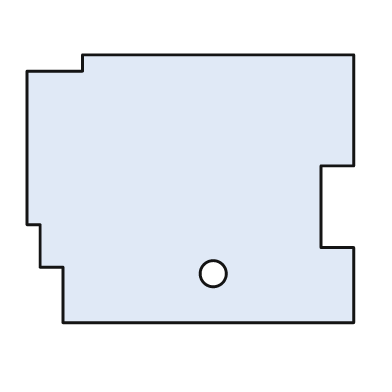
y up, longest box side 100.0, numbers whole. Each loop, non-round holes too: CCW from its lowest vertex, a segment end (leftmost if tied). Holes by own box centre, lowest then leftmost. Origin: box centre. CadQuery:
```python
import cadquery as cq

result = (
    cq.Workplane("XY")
    .moveTo(-39.0, -41.0)
    .lineTo(50.0, -41.0)
    .lineTo(50.0, -18.0)
    .lineTo(40.0, -18.0)
    .lineTo(40.0, 7.0)
    .lineTo(50.0, 7.0)
    .lineTo(50.0, 41.0)
    .lineTo(-33.0, 41.0)
    .lineTo(-33.0, 36.0)
    .lineTo(-50.0, 36.0)
    .lineTo(-50.0, -11.0)
    .lineTo(-46.0, -11.0)
    .lineTo(-46.0, -24.0)
    .lineTo(-39.0, -24.0)
    .close()
    .moveTo(7.0, -26.0)
    .circle(4.0)
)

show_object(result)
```